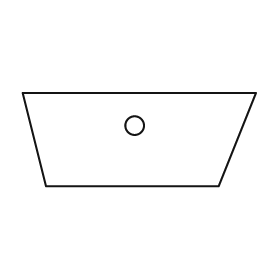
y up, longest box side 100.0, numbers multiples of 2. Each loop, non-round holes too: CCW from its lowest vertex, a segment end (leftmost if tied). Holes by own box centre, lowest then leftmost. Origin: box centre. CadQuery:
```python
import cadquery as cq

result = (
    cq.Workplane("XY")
    .moveTo(-40.0, -20.0)
    .lineTo(34.0, -20.0)
    .lineTo(50.0, 20.0)
    .lineTo(-50.0, 20.0)
    .close()
    .moveTo(-2.0, 6.0)
    .circle(4.0)
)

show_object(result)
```